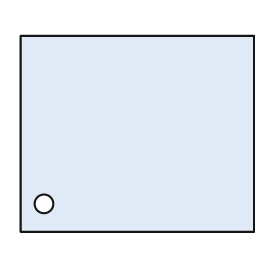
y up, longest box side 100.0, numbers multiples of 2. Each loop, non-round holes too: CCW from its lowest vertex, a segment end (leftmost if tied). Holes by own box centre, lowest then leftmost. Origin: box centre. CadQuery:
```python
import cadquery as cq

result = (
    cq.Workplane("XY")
    .moveTo(-50.0, -42.0)
    .lineTo(50.0, -42.0)
    .lineTo(50.0, 42.0)
    .lineTo(-50.0, 42.0)
    .close()
    .moveTo(-40.0, -30.0)
    .circle(4.0)
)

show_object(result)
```